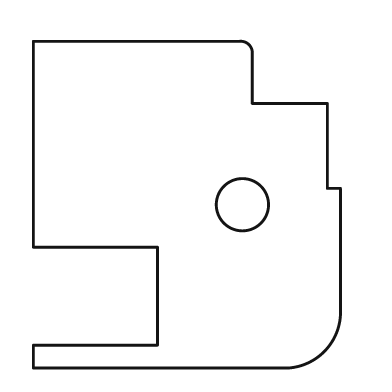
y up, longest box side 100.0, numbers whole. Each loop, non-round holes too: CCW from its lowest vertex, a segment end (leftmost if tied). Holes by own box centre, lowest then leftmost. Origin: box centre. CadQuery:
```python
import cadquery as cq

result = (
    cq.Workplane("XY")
    .moveTo(-47.0, -50.0)
    .lineTo(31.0, -50.0)
    .threePointArc((42.0, -45.0), (47.0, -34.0))
    .lineTo(47.0, 5.0)
    .lineTo(43.0, 5.0)
    .lineTo(43.0, 31.0)
    .lineTo(20.0, 31.0)
    .lineTo(20.0, 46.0)
    .threePointArc((19.0, 49.0), (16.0, 50.0))
    .lineTo(-47.0, 50.0)
    .lineTo(-47.0, -13.0)
    .lineTo(-9.0, -13.0)
    .lineTo(-9.0, -43.0)
    .lineTo(-47.0, -43.0)
    .close()
    .moveTo(17.0, 0.0)
    .circle(8.0)
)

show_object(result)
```